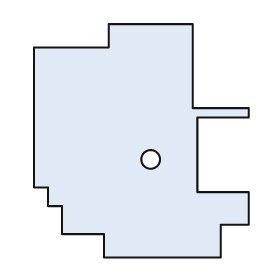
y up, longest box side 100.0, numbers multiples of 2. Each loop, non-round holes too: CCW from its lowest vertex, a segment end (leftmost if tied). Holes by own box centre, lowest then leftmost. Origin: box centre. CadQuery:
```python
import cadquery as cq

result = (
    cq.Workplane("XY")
    .moveTo(-16.0, -50.0)
    .lineTo(34.0, -50.0)
    .lineTo(34.0, -36.0)
    .lineTo(46.0, -36.0)
    .lineTo(46.0, -22.0)
    .lineTo(24.0, -22.0)
    .lineTo(24.0, 10.0)
    .lineTo(46.0, 10.0)
    .lineTo(46.0, 14.0)
    .lineTo(22.0, 14.0)
    .lineTo(22.0, 50.0)
    .lineTo(-14.0, 50.0)
    .lineTo(-14.0, 40.0)
    .lineTo(-46.0, 40.0)
    .lineTo(-46.0, -20.0)
    .lineTo(-40.0, -20.0)
    .lineTo(-40.0, -28.0)
    .lineTo(-34.0, -28.0)
    .lineTo(-34.0, -40.0)
    .lineTo(-16.0, -40.0)
    .close()
    .moveTo(4.0, -8.0)
    .circle(4.0)
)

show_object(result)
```